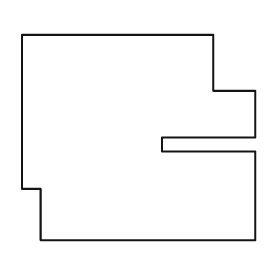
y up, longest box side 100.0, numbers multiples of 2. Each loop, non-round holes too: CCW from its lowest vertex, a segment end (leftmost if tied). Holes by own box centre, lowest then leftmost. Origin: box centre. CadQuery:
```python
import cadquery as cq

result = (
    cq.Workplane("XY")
    .moveTo(-42.0, -44.0)
    .lineTo(50.0, -44.0)
    .lineTo(50.0, -6.0)
    .lineTo(10.0, -6.0)
    .lineTo(10.0, 0.0)
    .lineTo(50.0, 0.0)
    .lineTo(50.0, 20.0)
    .lineTo(32.0, 20.0)
    .lineTo(32.0, 44.0)
    .lineTo(-50.0, 44.0)
    .lineTo(-50.0, -22.0)
    .lineTo(-42.0, -22.0)
    .close()
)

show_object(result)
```